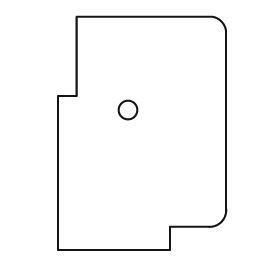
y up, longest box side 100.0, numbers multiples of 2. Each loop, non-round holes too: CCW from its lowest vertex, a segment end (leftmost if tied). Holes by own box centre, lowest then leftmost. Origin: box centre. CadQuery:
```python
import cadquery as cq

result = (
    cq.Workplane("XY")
    .moveTo(-36.0, -50.0)
    .lineTo(12.0, -50.0)
    .lineTo(12.0, -40.0)
    .lineTo(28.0, -40.0)
    .threePointArc((34.0, -38.0), (36.0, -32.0))
    .lineTo(36.0, 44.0)
    .threePointArc((34.0, 48.0), (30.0, 50.0))
    .lineTo(-28.0, 50.0)
    .lineTo(-28.0, 16.0)
    .lineTo(-36.0, 16.0)
    .close()
    .moveTo(-6.0, 10.0)
    .circle(4.0)
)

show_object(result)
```